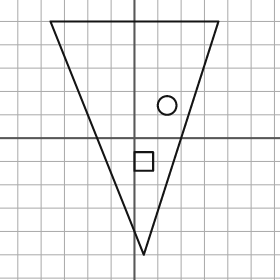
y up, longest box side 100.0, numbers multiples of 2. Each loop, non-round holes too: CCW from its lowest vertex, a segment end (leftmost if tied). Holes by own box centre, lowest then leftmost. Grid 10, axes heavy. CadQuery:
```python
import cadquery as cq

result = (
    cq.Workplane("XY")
    .moveTo(4.0, -50.0)
    .lineTo(36.0, 50.0)
    .lineTo(-36.0, 50.0)
    .close()
    .moveTo(0.0, -14.0)
    .lineTo(8.0, -14.0)
    .lineTo(8.0, -6.0)
    .lineTo(0.0, -6.0)
    .close()
    .moveTo(14.0, 14.0)
    .circle(4.0)
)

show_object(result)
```